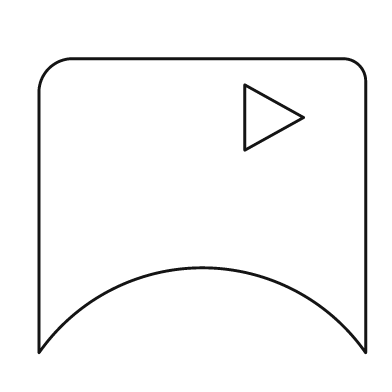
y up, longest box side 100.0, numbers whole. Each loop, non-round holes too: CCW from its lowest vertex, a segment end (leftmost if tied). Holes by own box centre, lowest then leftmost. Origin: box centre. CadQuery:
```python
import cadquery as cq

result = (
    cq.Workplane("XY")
    .moveTo(-50.0, -45.0)
    .threePointArc((0.0, -19.0), (50.0, -45.0))
    .lineTo(50.0, 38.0)
    .threePointArc((48.0, 43.0), (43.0, 45.0))
    .lineTo(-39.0, 45.0)
    .threePointArc((-47.0, 42.0), (-50.0, 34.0))
    .close()
    .moveTo(13.0, 17.0)
    .lineTo(31.0, 27.0)
    .lineTo(13.0, 37.0)
    .close()
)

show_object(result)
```